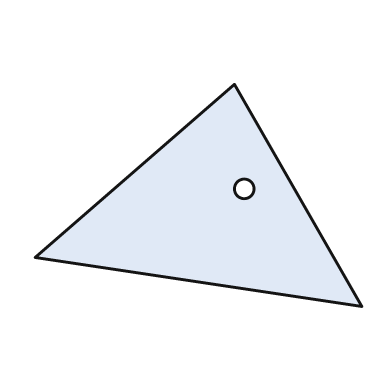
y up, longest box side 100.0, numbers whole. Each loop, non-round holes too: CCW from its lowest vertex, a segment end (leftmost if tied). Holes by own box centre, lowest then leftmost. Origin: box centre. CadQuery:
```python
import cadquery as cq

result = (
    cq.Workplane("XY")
    .moveTo(50.0, -34.0)
    .lineTo(11.0, 34.0)
    .lineTo(-50.0, -19.0)
    .close()
    .moveTo(14.0, 2.0)
    .circle(3.0)
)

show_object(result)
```